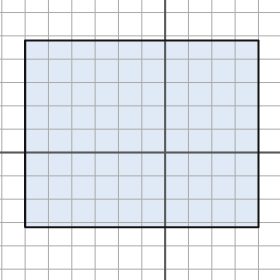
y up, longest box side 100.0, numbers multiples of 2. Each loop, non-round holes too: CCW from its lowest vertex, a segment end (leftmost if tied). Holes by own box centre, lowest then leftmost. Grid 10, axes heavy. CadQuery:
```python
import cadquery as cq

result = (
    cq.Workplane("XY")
    .moveTo(-60.0, -32.0)
    .lineTo(40.0, -32.0)
    .lineTo(40.0, 48.0)
    .lineTo(-60.0, 48.0)
    .close()
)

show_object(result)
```